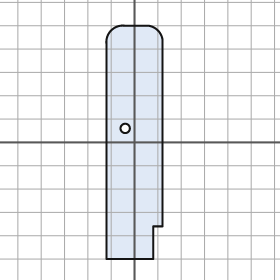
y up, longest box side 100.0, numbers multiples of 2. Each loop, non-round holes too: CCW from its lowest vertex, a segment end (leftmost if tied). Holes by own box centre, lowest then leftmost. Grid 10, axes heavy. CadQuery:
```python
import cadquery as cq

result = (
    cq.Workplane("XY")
    .moveTo(-12.0, -50.0)
    .lineTo(8.0, -50.0)
    .lineTo(8.0, -36.0)
    .lineTo(12.0, -36.0)
    .lineTo(12.0, 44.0)
    .threePointArc((10.0, 48.0), (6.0, 50.0))
    .lineTo(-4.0, 50.0)
    .threePointArc((-10.0, 48.0), (-12.0, 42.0))
    .close()
    .moveTo(-4.0, 6.0)
    .circle(2.0)
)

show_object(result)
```